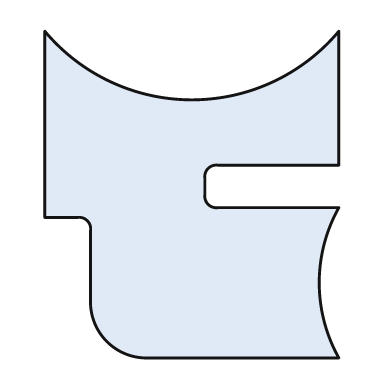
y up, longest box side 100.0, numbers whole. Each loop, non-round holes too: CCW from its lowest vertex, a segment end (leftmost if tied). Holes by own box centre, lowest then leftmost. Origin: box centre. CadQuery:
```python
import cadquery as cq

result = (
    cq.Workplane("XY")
    .moveTo(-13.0, -50.0)
    .lineTo(45.0, -50.0)
    .threePointArc((39.0, -27.0), (45.0, -4.0))
    .lineTo(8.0, -4.0)
    .threePointArc((5.0, -3.0), (4.0, 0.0))
    .lineTo(4.0, 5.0)
    .threePointArc((5.0, 8.0), (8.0, 9.0))
    .lineTo(45.0, 9.0)
    .lineTo(45.0, 50.0)
    .threePointArc((0.0, 29.0), (-45.0, 50.0))
    .lineTo(-45.0, -7.0)
    .lineTo(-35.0, -7.0)
    .threePointArc((-32.0, -8.0), (-31.0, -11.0))
    .lineTo(-31.0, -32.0)
    .threePointArc((-26.0, -45.0), (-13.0, -50.0))
    .close()
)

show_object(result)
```